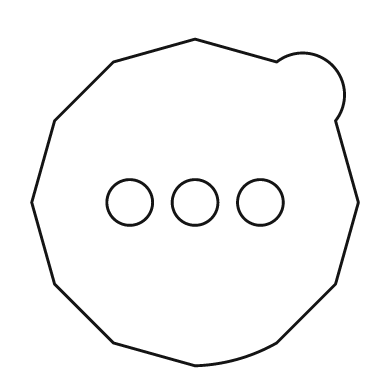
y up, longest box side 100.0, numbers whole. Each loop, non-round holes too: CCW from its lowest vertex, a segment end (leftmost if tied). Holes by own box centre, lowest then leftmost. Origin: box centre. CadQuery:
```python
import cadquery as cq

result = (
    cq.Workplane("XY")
    .moveTo(0.0, -50.0)
    .threePointArc((13.0, -48.0), (25.0, -43.0))
    .lineTo(43.0, -25.0)
    .lineTo(50.0, 0.0)
    .lineTo(43.0, 25.0)
    .threePointArc((42.0, 42.0), (25.0, 43.0))
    .lineTo(0.0, 50.0)
    .lineTo(-25.0, 43.0)
    .lineTo(-43.0, 25.0)
    .lineTo(-50.0, 0.0)
    .lineTo(-43.0, -25.0)
    .lineTo(-25.0, -43.0)
    .close()
    .moveTo(-20.0, 0.0)
    .circle(7.0)
    .moveTo(0.0, 0.0)
    .circle(7.0)
    .moveTo(20.0, 0.0)
    .circle(7.0)
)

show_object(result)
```